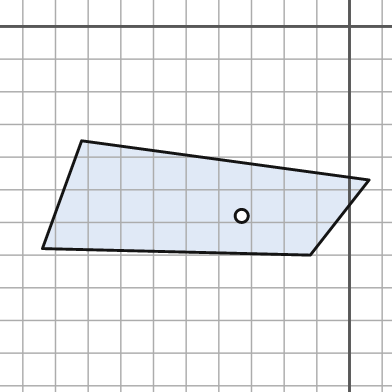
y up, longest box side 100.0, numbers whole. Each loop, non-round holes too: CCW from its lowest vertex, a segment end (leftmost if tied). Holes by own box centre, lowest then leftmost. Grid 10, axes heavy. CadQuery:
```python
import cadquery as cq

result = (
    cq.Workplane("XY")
    .moveTo(-12.0, -70.0)
    .lineTo(6.0, -47.0)
    .lineTo(-82.0, -35.0)
    .lineTo(-94.0, -68.0)
    .close()
    .moveTo(-33.0, -58.0)
    .circle(2.0)
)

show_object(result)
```